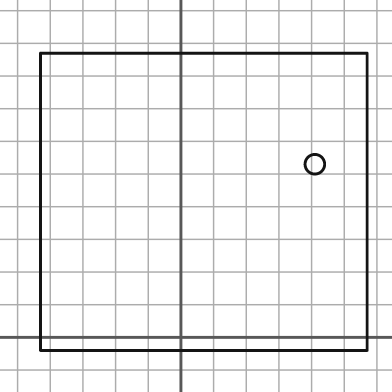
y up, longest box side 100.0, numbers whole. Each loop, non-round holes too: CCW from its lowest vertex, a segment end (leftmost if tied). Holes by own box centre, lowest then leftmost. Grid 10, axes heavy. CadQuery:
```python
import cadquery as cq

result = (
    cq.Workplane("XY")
    .moveTo(-43.0, -4.0)
    .lineTo(57.0, -4.0)
    .lineTo(57.0, 87.0)
    .lineTo(-43.0, 87.0)
    .close()
    .moveTo(41.0, 53.0)
    .circle(3.0)
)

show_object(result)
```